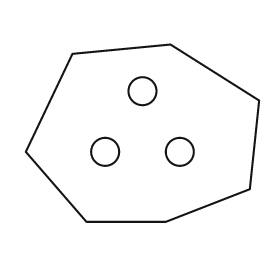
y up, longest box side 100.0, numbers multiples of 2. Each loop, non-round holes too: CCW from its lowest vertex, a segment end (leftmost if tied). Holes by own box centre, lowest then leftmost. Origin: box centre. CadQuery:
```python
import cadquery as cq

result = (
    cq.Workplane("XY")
    .moveTo(-24.0, -38.0)
    .lineTo(10.0, -38.0)
    .lineTo(46.0, -24.0)
    .lineTo(50.0, 14.0)
    .lineTo(12.0, 38.0)
    .lineTo(-30.0, 34.0)
    .lineTo(-50.0, -8.0)
    .close()
    .moveTo(-16.0, -8.0)
    .circle(6.0)
    .moveTo(16.0, -8.0)
    .circle(6.0)
    .moveTo(0.0, 18.0)
    .circle(6.0)
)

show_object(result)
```